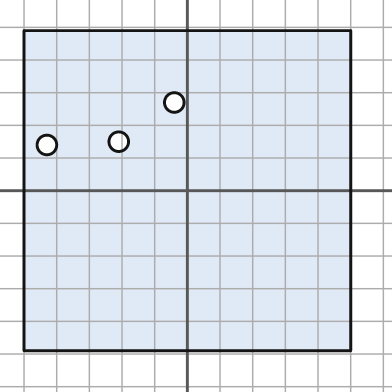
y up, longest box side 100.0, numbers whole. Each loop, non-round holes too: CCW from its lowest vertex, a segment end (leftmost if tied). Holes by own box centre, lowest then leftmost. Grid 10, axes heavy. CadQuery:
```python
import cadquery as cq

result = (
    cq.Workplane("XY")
    .moveTo(-50.0, -49.0)
    .lineTo(50.0, -49.0)
    .lineTo(50.0, 49.0)
    .lineTo(-50.0, 49.0)
    .close()
    .moveTo(-43.0, 14.0)
    .circle(3.0)
    .moveTo(-21.0, 15.0)
    .circle(3.0)
    .moveTo(-4.0, 27.0)
    .circle(3.0)
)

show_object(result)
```